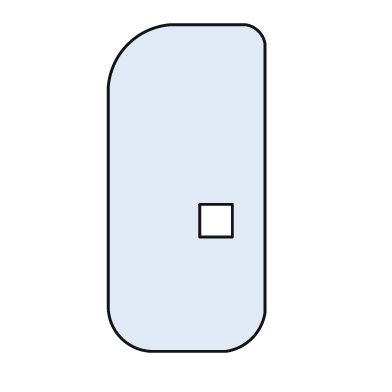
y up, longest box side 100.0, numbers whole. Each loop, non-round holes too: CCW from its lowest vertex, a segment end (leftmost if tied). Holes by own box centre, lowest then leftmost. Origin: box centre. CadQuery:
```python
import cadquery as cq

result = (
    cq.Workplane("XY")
    .moveTo(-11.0, -50.0)
    .lineTo(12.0, -50.0)
    .threePointArc((20.0, -46.0), (24.0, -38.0))
    .lineTo(24.0, 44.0)
    .threePointArc((22.0, 48.0), (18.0, 50.0))
    .lineTo(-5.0, 50.0)
    .threePointArc((-18.0, 44.0), (-24.0, 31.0))
    .lineTo(-24.0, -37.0)
    .threePointArc((-20.0, -46.0), (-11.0, -50.0))
    .close()
    .moveTo(4.0, -15.0)
    .lineTo(14.0, -15.0)
    .lineTo(14.0, -5.0)
    .lineTo(4.0, -5.0)
    .close()
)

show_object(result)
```